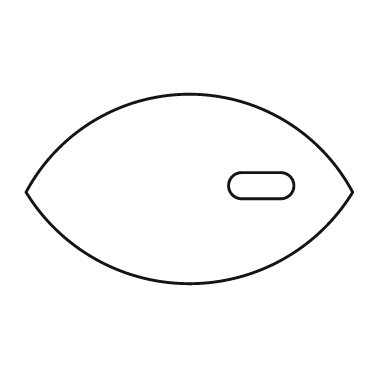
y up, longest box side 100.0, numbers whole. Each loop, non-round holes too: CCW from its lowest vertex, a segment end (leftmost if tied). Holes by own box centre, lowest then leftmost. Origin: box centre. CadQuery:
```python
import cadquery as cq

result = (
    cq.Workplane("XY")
    .moveTo(-50.0, -1.0)
    .threePointArc((0.0, -29.0), (50.0, -1.0))
    .threePointArc((0.0, 29.0), (-50.0, -1.0))
    .close()
    .moveTo(16.0, -3.0)
    .lineTo(28.0, -3.0)
    .threePointArc((32.0, 1.0), (28.0, 5.0))
    .lineTo(16.0, 5.0)
    .threePointArc((12.0, 1.0), (16.0, -3.0))
    .close()
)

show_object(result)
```